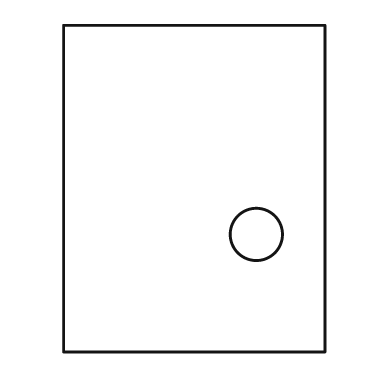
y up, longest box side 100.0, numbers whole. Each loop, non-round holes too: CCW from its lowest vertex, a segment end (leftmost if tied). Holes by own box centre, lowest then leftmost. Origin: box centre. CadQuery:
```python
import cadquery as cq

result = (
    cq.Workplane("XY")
    .moveTo(-40.0, -50.0)
    .lineTo(40.0, -50.0)
    .lineTo(40.0, 50.0)
    .lineTo(-40.0, 50.0)
    .close()
    .moveTo(19.0, -14.0)
    .circle(8.0)
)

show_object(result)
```